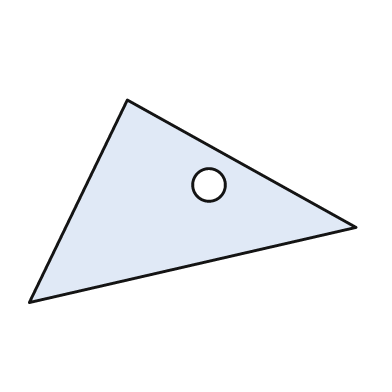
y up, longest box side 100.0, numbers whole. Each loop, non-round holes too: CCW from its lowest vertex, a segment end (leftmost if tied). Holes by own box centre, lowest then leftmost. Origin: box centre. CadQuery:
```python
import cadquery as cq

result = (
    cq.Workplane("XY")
    .moveTo(-50.0, -31.0)
    .lineTo(50.0, -8.0)
    .lineTo(-20.0, 31.0)
    .close()
    .moveTo(5.0, 5.0)
    .circle(5.0)
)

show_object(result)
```